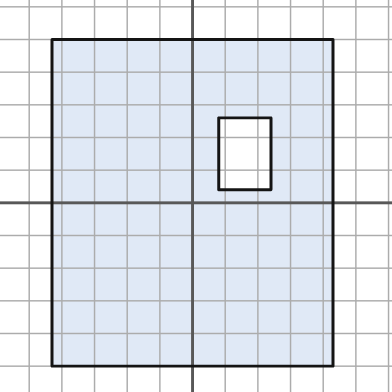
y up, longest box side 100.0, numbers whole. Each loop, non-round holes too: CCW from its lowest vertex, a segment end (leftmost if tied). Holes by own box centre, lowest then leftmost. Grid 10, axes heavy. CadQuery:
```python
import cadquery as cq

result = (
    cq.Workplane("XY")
    .moveTo(-43.0, -50.0)
    .lineTo(43.0, -50.0)
    .lineTo(43.0, 50.0)
    .lineTo(-43.0, 50.0)
    .close()
    .moveTo(8.0, 4.0)
    .lineTo(24.0, 4.0)
    .lineTo(24.0, 26.0)
    .lineTo(8.0, 26.0)
    .close()
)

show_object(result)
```